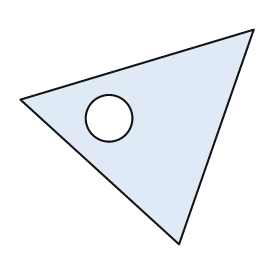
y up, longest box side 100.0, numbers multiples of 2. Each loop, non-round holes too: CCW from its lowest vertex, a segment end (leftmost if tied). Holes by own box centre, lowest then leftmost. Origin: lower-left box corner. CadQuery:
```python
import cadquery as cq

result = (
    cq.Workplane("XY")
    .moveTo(68.0, 0.0)
    .lineTo(100.0, 92.0)
    .lineTo(0.0, 62.0)
    .close()
    .moveTo(38.0, 54.0)
    .circle(10.0)
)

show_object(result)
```